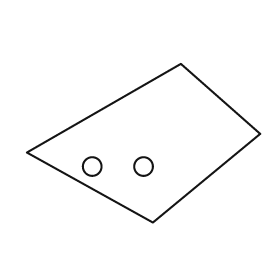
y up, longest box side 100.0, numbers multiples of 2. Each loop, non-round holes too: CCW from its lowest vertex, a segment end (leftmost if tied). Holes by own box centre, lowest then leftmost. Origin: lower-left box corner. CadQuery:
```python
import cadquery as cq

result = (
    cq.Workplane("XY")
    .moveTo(54.0, 0.0)
    .lineTo(100.0, 38.0)
    .lineTo(66.0, 68.0)
    .lineTo(0.0, 30.0)
    .close()
    .moveTo(28.0, 24.0)
    .circle(4.0)
    .moveTo(50.0, 24.0)
    .circle(4.0)
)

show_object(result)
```